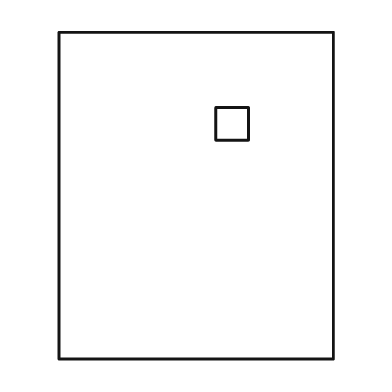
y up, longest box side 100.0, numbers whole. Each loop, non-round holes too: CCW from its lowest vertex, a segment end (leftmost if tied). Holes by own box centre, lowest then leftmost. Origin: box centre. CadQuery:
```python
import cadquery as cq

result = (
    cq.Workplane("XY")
    .moveTo(-42.0, -50.0)
    .lineTo(42.0, -50.0)
    .lineTo(42.0, 50.0)
    .lineTo(-42.0, 50.0)
    .close()
    .moveTo(6.0, 17.0)
    .lineTo(16.0, 17.0)
    .lineTo(16.0, 27.0)
    .lineTo(6.0, 27.0)
    .close()
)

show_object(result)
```